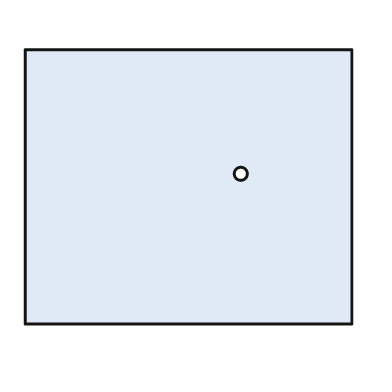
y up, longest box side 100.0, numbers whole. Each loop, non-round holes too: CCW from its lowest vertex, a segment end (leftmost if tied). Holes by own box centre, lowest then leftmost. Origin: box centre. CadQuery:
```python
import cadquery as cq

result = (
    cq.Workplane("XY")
    .moveTo(-50.0, -42.0)
    .lineTo(50.0, -42.0)
    .lineTo(50.0, 42.0)
    .lineTo(-50.0, 42.0)
    .close()
    .moveTo(16.0, 4.0)
    .circle(2.0)
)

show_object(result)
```